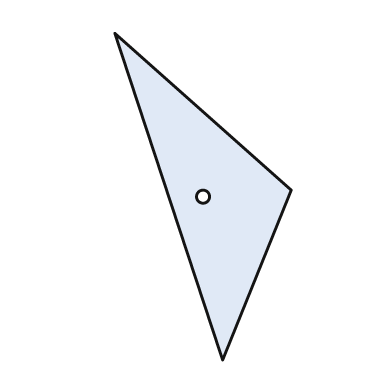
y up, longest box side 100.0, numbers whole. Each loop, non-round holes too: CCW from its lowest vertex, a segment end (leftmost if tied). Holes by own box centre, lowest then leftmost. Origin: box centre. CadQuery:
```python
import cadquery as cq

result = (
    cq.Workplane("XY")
    .moveTo(6.0, -50.0)
    .lineTo(27.0, 2.0)
    .lineTo(-27.0, 50.0)
    .close()
    .moveTo(0.0, 0.0)
    .circle(2.0)
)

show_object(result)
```